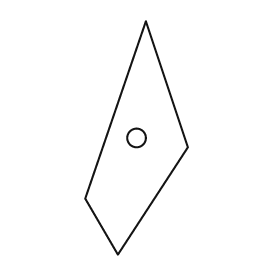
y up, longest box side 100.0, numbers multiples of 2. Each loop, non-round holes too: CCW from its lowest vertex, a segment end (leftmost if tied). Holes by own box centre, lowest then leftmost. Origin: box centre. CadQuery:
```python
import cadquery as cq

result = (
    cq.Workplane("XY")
    .moveTo(-8.0, -50.0)
    .lineTo(22.0, -4.0)
    .lineTo(4.0, 50.0)
    .lineTo(-22.0, -26.0)
    .close()
    .moveTo(0.0, 0.0)
    .circle(4.0)
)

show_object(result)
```